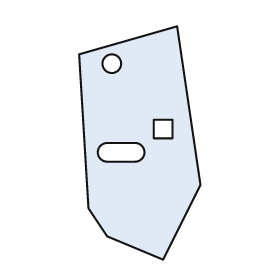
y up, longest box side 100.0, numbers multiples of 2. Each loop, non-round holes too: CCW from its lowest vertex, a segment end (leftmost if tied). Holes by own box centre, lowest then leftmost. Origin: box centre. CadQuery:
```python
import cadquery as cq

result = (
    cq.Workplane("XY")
    .moveTo(10.0, -50.0)
    .lineTo(26.0, -18.0)
    .lineTo(16.0, 50.0)
    .lineTo(-26.0, 38.0)
    .lineTo(-22.0, -28.0)
    .lineTo(-14.0, -40.0)
    .close()
    .moveTo(-14.0, -8.0)
    .lineTo(-2.0, -8.0)
    .threePointArc((2.0, -4.0), (-2.0, 0.0))
    .lineTo(-14.0, 0.0)
    .threePointArc((-18.0, -4.0), (-14.0, -8.0))
    .close()
    .moveTo(6.0, 2.0)
    .lineTo(14.0, 2.0)
    .lineTo(14.0, 10.0)
    .lineTo(6.0, 10.0)
    .close()
    .moveTo(-12.0, 34.0)
    .circle(4.0)
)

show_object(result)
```